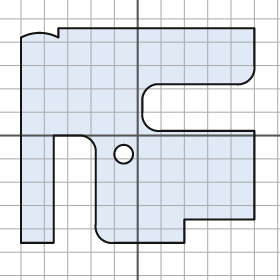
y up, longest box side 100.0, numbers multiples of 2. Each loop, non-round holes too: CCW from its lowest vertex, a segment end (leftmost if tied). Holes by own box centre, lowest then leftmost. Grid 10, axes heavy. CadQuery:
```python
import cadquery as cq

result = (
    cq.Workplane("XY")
    .moveTo(-50.0, -46.0)
    .lineTo(-36.0, -46.0)
    .lineTo(-36.0, 0.0)
    .lineTo(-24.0, 0.0)
    .threePointArc((-20.0, -2.0), (-18.0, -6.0))
    .lineTo(-18.0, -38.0)
    .threePointArc((-16.0, -44.0), (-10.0, -46.0))
    .lineTo(20.0, -46.0)
    .lineTo(20.0, -36.0)
    .lineTo(50.0, -36.0)
    .lineTo(50.0, 2.0)
    .lineTo(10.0, 2.0)
    .threePointArc((4.0, 4.0), (2.0, 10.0))
    .lineTo(2.0, 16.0)
    .threePointArc((4.0, 20.0), (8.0, 22.0))
    .lineTo(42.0, 22.0)
    .threePointArc((48.0, 24.0), (50.0, 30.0))
    .lineTo(50.0, 46.0)
    .lineTo(-34.0, 46.0)
    .lineTo(-34.0, 42.0)
    .threePointArc((-42.0, 44.0), (-50.0, 42.0))
    .close()
    .moveTo(-6.0, -8.0)
    .circle(4.0)
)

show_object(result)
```